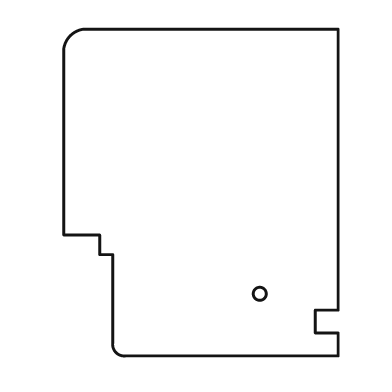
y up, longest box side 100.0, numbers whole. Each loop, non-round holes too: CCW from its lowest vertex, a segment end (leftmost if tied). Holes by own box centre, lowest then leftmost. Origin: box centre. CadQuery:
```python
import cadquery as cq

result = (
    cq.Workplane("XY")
    .moveTo(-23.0, -50.0)
    .lineTo(42.0, -50.0)
    .lineTo(42.0, -43.0)
    .lineTo(35.0, -43.0)
    .lineTo(35.0, -36.0)
    .lineTo(42.0, -36.0)
    .lineTo(42.0, 50.0)
    .lineTo(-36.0, 50.0)
    .threePointArc((-40.0, 48.0), (-42.0, 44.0))
    .lineTo(-42.0, -13.0)
    .lineTo(-31.0, -13.0)
    .lineTo(-31.0, -19.0)
    .lineTo(-27.0, -19.0)
    .lineTo(-27.0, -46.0)
    .threePointArc((-26.0, -49.0), (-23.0, -50.0))
    .close()
    .moveTo(18.0, -31.0)
    .circle(2.0)
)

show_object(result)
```